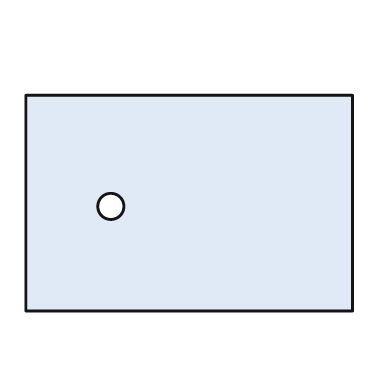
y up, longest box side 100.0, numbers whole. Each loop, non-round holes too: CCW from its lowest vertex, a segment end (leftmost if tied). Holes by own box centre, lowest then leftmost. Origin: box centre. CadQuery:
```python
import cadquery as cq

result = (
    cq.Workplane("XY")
    .moveTo(-50.0, -33.0)
    .lineTo(50.0, -33.0)
    .lineTo(50.0, 33.0)
    .lineTo(-50.0, 33.0)
    .close()
    .moveTo(-24.0, -1.0)
    .circle(4.0)
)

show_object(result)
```